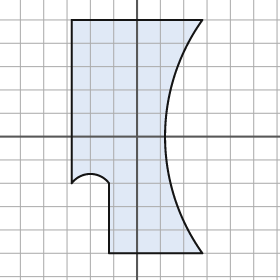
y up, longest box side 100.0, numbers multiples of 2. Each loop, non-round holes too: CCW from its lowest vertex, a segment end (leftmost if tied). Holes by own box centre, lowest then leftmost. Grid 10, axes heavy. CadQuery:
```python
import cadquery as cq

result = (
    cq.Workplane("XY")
    .moveTo(-12.0, -50.0)
    .lineTo(28.0, -50.0)
    .threePointArc((12.0, 0.0), (28.0, 50.0))
    .lineTo(-28.0, 50.0)
    .lineTo(-28.0, -20.0)
    .threePointArc((-20.0, -16.0), (-12.0, -20.0))
    .close()
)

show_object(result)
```